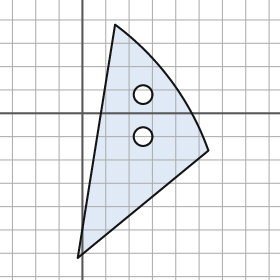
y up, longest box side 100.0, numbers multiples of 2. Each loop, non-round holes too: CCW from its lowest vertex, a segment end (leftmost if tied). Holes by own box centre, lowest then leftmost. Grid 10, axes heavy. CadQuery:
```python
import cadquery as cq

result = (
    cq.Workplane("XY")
    .moveTo(-2.0, -62.0)
    .lineTo(54.0, -16.0)
    .threePointArc((38.0, 14.0), (14.0, 38.0))
    .close()
    .moveTo(26.0, -10.0)
    .circle(4.0)
    .moveTo(26.0, 8.0)
    .circle(4.0)
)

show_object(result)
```